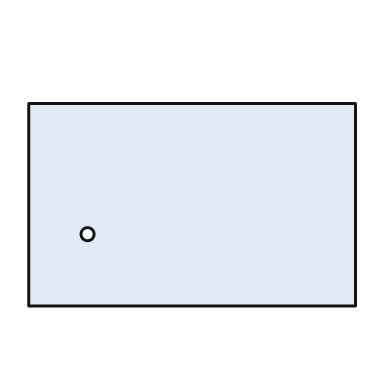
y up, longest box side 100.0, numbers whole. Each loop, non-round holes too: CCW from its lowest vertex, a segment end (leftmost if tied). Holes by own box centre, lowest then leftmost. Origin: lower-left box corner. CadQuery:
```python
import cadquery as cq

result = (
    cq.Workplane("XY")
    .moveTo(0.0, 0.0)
    .lineTo(100.0, 0.0)
    .lineTo(100.0, 62.0)
    .lineTo(0.0, 62.0)
    .close()
    .moveTo(18.0, 22.0)
    .circle(2.0)
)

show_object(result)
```